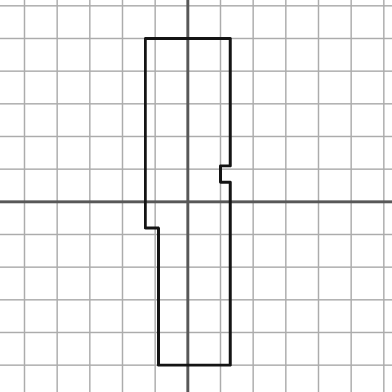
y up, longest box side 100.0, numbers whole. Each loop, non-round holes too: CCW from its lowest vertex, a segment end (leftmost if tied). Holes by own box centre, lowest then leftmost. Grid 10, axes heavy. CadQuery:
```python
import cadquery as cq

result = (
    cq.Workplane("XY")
    .moveTo(-9.0, -50.0)
    .lineTo(13.0, -50.0)
    .lineTo(13.0, 6.0)
    .lineTo(10.0, 6.0)
    .lineTo(10.0, 11.0)
    .lineTo(13.0, 11.0)
    .lineTo(13.0, 50.0)
    .lineTo(-13.0, 50.0)
    .lineTo(-13.0, -8.0)
    .lineTo(-9.0, -8.0)
    .close()
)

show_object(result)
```